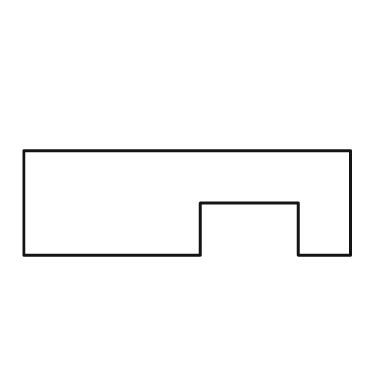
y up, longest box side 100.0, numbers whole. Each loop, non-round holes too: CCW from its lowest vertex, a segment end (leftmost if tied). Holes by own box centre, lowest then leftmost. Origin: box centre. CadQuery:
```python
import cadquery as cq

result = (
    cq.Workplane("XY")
    .moveTo(-50.0, -16.0)
    .lineTo(4.0, -16.0)
    .lineTo(4.0, 0.0)
    .lineTo(34.0, 0.0)
    .lineTo(34.0, -16.0)
    .lineTo(50.0, -16.0)
    .lineTo(50.0, 16.0)
    .lineTo(-50.0, 16.0)
    .close()
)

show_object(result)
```